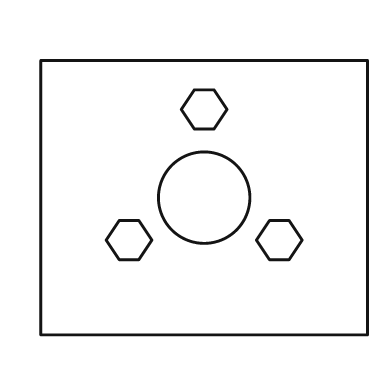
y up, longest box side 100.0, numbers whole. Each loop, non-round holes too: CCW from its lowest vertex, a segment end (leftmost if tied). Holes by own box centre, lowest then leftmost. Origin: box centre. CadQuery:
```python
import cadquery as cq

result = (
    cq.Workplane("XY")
    .moveTo(-50.0, -42.0)
    .lineTo(50.0, -42.0)
    .lineTo(50.0, 42.0)
    .lineTo(-50.0, 42.0)
    .close()
    .moveTo(-26.0, -19.0)
    .lineTo(-20.0, -19.0)
    .lineTo(-16.0, -13.0)
    .lineTo(-20.0, -7.0)
    .lineTo(-26.0, -7.0)
    .lineTo(-30.0, -13.0)
    .close()
    .moveTo(20.0, -19.0)
    .lineTo(26.0, -19.0)
    .lineTo(30.0, -13.0)
    .lineTo(26.0, -7.0)
    .lineTo(20.0, -7.0)
    .lineTo(16.0, -13.0)
    .close()
    .moveTo(0.0, 0.0)
    .circle(14.0)
    .moveTo(-3.0, 21.0)
    .lineTo(3.0, 21.0)
    .lineTo(7.0, 27.0)
    .lineTo(3.0, 33.0)
    .lineTo(-3.0, 33.0)
    .lineTo(-7.0, 27.0)
    .close()
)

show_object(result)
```